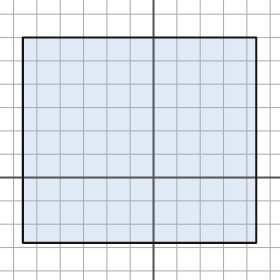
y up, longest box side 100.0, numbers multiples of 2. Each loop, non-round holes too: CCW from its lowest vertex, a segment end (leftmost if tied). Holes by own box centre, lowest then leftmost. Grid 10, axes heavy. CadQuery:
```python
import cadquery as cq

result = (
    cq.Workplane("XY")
    .moveTo(-56.0, -28.0)
    .lineTo(44.0, -28.0)
    .lineTo(44.0, 60.0)
    .lineTo(-56.0, 60.0)
    .close()
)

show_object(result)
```